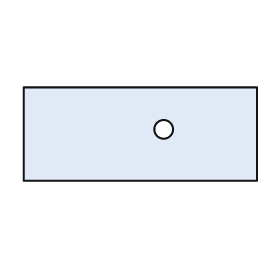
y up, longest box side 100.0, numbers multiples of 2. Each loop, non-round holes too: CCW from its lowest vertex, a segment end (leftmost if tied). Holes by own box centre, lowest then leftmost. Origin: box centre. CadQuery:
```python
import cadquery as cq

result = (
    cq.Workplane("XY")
    .moveTo(-50.0, -20.0)
    .lineTo(50.0, -20.0)
    .lineTo(50.0, 20.0)
    .lineTo(-50.0, 20.0)
    .close()
    .moveTo(10.0, 2.0)
    .circle(4.0)
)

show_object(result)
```